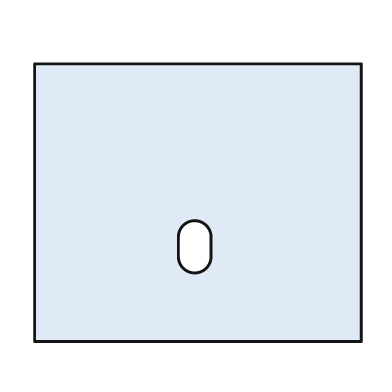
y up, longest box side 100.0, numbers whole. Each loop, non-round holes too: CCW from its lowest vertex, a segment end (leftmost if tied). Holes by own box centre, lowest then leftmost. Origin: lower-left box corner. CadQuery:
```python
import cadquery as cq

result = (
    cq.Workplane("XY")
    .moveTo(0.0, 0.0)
    .lineTo(100.0, 0.0)
    .lineTo(100.0, 85.0)
    .lineTo(0.0, 85.0)
    .close()
    .moveTo(44.0, 26.0)
    .threePointArc((49.0, 21.0), (54.0, 26.0))
    .lineTo(54.0, 32.0)
    .threePointArc((49.0, 37.0), (44.0, 32.0))
    .close()
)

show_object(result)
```